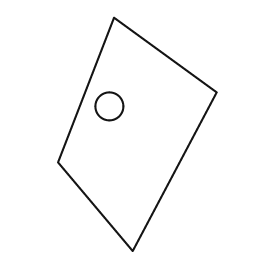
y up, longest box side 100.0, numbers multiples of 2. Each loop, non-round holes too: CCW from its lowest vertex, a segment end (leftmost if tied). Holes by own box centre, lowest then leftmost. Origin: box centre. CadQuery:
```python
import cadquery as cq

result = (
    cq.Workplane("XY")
    .moveTo(-2.0, -50.0)
    .lineTo(34.0, 18.0)
    .lineTo(-10.0, 50.0)
    .lineTo(-34.0, -12.0)
    .close()
    .moveTo(-12.0, 12.0)
    .circle(6.0)
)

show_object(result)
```